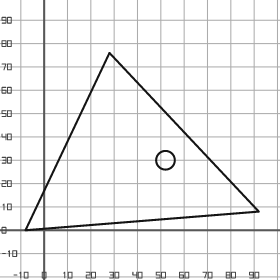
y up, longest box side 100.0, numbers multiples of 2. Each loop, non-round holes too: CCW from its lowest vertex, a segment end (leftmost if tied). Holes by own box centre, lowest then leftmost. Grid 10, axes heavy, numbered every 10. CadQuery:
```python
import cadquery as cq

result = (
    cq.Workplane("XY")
    .moveTo(-8.0, 0.0)
    .lineTo(92.0, 8.0)
    .lineTo(28.0, 76.0)
    .close()
    .moveTo(52.0, 30.0)
    .circle(4.0)
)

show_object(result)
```